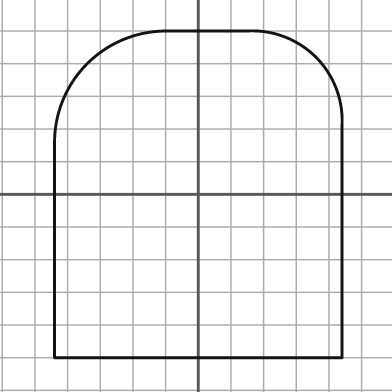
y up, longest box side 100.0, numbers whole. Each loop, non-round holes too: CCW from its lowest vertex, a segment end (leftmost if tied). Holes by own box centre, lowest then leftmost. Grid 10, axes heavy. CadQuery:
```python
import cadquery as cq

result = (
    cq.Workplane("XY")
    .moveTo(-44.0, -50.0)
    .lineTo(44.0, -50.0)
    .lineTo(44.0, 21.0)
    .threePointArc((36.0, 42.0), (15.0, 50.0))
    .lineTo(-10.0, 50.0)
    .threePointArc((-34.0, 40.0), (-44.0, 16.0))
    .close()
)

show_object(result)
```